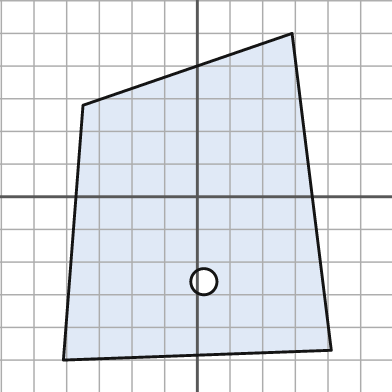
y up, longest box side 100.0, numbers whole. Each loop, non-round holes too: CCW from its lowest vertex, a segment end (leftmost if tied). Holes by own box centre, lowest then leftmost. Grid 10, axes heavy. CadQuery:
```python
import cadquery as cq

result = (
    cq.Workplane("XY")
    .moveTo(-41.0, -50.0)
    .lineTo(41.0, -47.0)
    .lineTo(29.0, 50.0)
    .lineTo(-35.0, 28.0)
    .close()
    .moveTo(2.0, -26.0)
    .circle(4.0)
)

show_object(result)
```